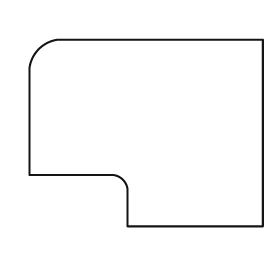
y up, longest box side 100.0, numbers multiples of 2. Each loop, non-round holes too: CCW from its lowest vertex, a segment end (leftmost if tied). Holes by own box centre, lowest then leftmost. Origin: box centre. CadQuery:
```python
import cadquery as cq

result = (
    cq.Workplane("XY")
    .moveTo(-8.0, -40.0)
    .lineTo(50.0, -40.0)
    .lineTo(50.0, 40.0)
    .lineTo(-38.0, 40.0)
    .threePointArc((-46.0, 36.0), (-50.0, 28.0))
    .lineTo(-50.0, -18.0)
    .lineTo(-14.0, -18.0)
    .threePointArc((-10.0, -20.0), (-8.0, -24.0))
    .close()
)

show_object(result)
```